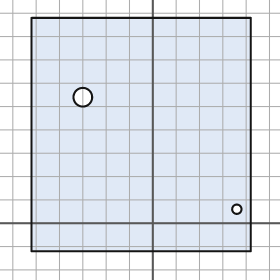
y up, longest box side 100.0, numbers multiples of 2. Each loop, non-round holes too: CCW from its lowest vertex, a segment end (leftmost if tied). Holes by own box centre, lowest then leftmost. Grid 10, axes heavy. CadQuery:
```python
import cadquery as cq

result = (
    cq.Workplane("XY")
    .moveTo(-52.0, -12.0)
    .lineTo(42.0, -12.0)
    .lineTo(42.0, 88.0)
    .lineTo(-52.0, 88.0)
    .close()
    .moveTo(36.0, 6.0)
    .circle(2.0)
    .moveTo(-30.0, 54.0)
    .circle(4.0)
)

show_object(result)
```